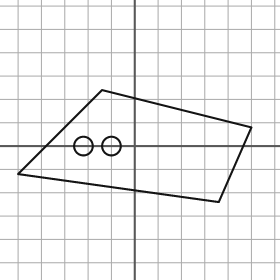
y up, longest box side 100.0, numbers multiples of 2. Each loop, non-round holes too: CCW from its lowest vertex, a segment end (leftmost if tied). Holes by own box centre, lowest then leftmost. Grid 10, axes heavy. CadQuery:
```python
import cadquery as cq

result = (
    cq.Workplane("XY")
    .moveTo(36.0, -24.0)
    .lineTo(50.0, 8.0)
    .lineTo(-14.0, 24.0)
    .lineTo(-50.0, -12.0)
    .close()
    .moveTo(-22.0, 0.0)
    .circle(4.0)
    .moveTo(-10.0, 0.0)
    .circle(4.0)
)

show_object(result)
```